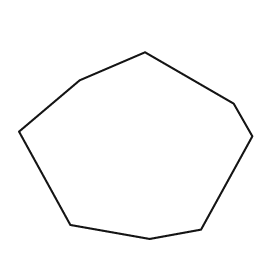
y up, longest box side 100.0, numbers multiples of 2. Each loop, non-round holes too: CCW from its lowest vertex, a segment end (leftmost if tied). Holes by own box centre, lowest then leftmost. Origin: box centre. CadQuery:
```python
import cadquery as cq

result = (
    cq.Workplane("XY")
    .moveTo(6.0, -40.0)
    .lineTo(28.0, -36.0)
    .lineTo(50.0, 4.0)
    .lineTo(42.0, 18.0)
    .lineTo(4.0, 40.0)
    .lineTo(-24.0, 28.0)
    .lineTo(-50.0, 6.0)
    .lineTo(-28.0, -34.0)
    .close()
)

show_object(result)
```